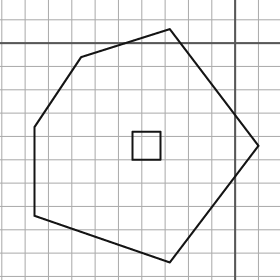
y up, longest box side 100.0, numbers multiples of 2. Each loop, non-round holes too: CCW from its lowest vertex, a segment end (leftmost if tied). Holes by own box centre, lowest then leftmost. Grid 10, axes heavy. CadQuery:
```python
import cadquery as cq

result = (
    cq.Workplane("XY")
    .moveTo(-28.0, -94.0)
    .lineTo(10.0, -44.0)
    .lineTo(-28.0, 6.0)
    .lineTo(-66.0, -6.0)
    .lineTo(-86.0, -36.0)
    .lineTo(-86.0, -74.0)
    .close()
    .moveTo(-44.0, -50.0)
    .lineTo(-32.0, -50.0)
    .lineTo(-32.0, -38.0)
    .lineTo(-44.0, -38.0)
    .close()
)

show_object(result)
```